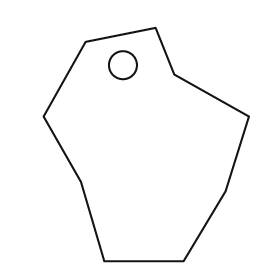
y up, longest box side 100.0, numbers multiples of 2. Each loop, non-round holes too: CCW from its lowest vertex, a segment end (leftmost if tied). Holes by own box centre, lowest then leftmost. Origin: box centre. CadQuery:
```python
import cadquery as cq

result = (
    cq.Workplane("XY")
    .moveTo(-18.0, -50.0)
    .lineTo(16.0, -50.0)
    .lineTo(34.0, -20.0)
    .lineTo(44.0, 12.0)
    .lineTo(12.0, 30.0)
    .lineTo(4.0, 50.0)
    .lineTo(-26.0, 44.0)
    .lineTo(-44.0, 12.0)
    .lineTo(-28.0, -16.0)
    .close()
    .moveTo(-10.0, 34.0)
    .circle(6.0)
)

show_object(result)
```